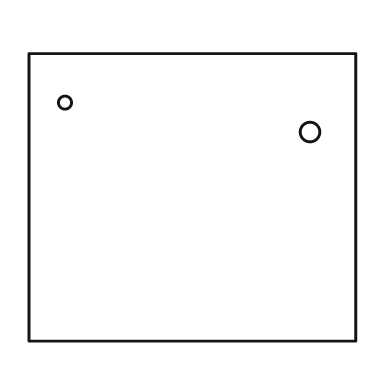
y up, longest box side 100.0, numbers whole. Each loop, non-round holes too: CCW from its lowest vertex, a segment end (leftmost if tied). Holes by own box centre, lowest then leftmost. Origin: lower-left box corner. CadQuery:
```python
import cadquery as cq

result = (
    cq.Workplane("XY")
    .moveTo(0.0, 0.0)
    .lineTo(100.0, 0.0)
    .lineTo(100.0, 88.0)
    .lineTo(0.0, 88.0)
    .close()
    .moveTo(86.0, 64.0)
    .circle(3.0)
    .moveTo(11.0, 73.0)
    .circle(2.0)
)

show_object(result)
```